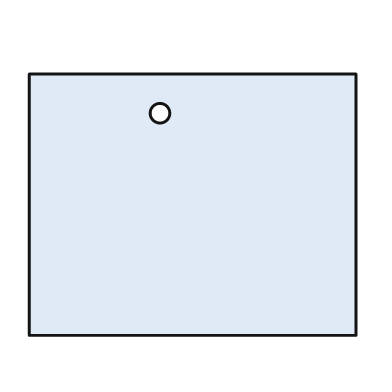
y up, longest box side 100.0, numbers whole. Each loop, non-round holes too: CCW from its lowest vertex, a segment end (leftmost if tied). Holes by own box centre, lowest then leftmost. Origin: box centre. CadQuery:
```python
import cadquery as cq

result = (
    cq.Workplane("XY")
    .moveTo(-50.0, -40.0)
    .lineTo(50.0, -40.0)
    .lineTo(50.0, 40.0)
    .lineTo(-50.0, 40.0)
    .close()
    .moveTo(-10.0, 28.0)
    .circle(3.0)
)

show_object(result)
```